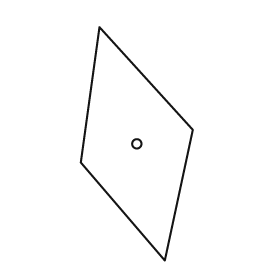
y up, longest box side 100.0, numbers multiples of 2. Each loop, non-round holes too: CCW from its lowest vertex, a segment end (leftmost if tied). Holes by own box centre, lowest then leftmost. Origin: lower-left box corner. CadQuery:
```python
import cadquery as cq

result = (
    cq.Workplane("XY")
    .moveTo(36.0, 0.0)
    .lineTo(48.0, 56.0)
    .lineTo(8.0, 100.0)
    .lineTo(0.0, 42.0)
    .close()
    .moveTo(24.0, 50.0)
    .circle(2.0)
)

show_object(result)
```